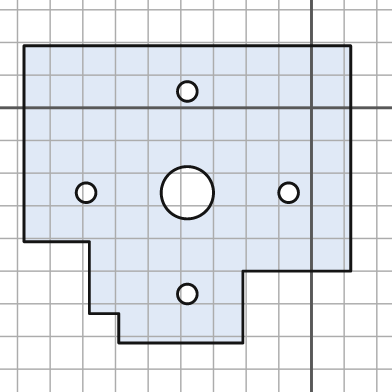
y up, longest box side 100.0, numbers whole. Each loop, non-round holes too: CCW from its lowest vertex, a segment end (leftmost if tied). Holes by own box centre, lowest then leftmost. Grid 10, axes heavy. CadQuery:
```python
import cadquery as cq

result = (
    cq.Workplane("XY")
    .moveTo(-59.0, -72.0)
    .lineTo(-21.0, -72.0)
    .lineTo(-21.0, -50.0)
    .lineTo(12.0, -50.0)
    .lineTo(12.0, 19.0)
    .lineTo(-88.0, 19.0)
    .lineTo(-88.0, -41.0)
    .lineTo(-68.0, -41.0)
    .lineTo(-68.0, -63.0)
    .lineTo(-59.0, -63.0)
    .close()
    .moveTo(-38.0, -57.0)
    .circle(3.0)
    .moveTo(-69.0, -26.0)
    .circle(3.0)
    .moveTo(-38.0, -26.0)
    .circle(8.0)
    .moveTo(-7.0, -26.0)
    .circle(3.0)
    .moveTo(-38.0, 5.0)
    .circle(3.0)
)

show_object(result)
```